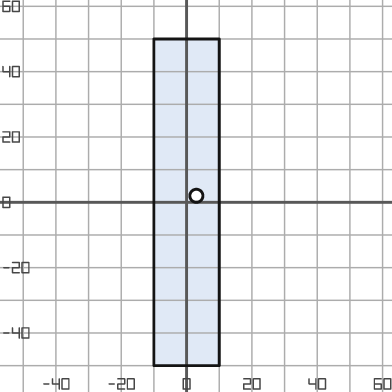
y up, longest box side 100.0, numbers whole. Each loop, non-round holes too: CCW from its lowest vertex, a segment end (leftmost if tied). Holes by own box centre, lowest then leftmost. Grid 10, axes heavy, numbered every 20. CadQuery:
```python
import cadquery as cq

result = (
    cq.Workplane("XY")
    .moveTo(-10.0, -50.0)
    .lineTo(10.0, -50.0)
    .lineTo(10.0, 50.0)
    .lineTo(-10.0, 50.0)
    .close()
    .moveTo(3.0, 2.0)
    .circle(2.0)
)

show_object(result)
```